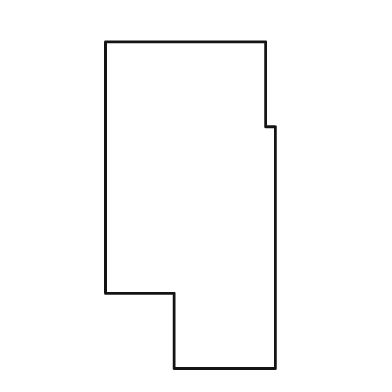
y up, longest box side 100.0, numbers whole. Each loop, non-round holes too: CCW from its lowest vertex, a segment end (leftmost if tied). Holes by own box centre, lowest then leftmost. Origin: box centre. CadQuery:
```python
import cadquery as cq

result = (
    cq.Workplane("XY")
    .moveTo(-5.0, -50.0)
    .lineTo(26.0, -50.0)
    .lineTo(26.0, 24.0)
    .lineTo(23.0, 24.0)
    .lineTo(23.0, 50.0)
    .lineTo(-26.0, 50.0)
    .lineTo(-26.0, -27.0)
    .lineTo(-5.0, -27.0)
    .close()
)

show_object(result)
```